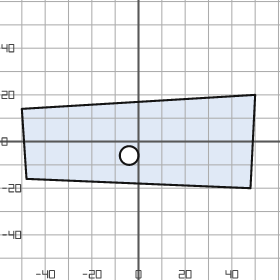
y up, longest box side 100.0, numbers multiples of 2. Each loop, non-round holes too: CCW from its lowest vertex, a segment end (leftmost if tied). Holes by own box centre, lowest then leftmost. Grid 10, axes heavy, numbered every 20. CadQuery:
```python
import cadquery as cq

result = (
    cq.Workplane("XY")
    .moveTo(48.0, -20.0)
    .lineTo(50.0, 20.0)
    .lineTo(-50.0, 14.0)
    .lineTo(-48.0, -16.0)
    .close()
    .moveTo(-4.0, -6.0)
    .circle(4.0)
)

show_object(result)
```